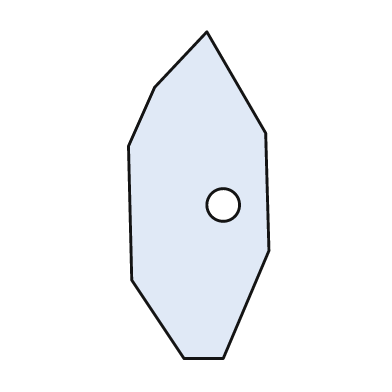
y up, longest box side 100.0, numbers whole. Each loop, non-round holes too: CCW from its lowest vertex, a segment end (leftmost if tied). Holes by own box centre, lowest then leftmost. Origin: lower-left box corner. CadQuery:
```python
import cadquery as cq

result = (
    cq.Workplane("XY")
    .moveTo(17.0, 0.0)
    .lineTo(29.0, 0.0)
    .lineTo(43.0, 33.0)
    .lineTo(42.0, 69.0)
    .lineTo(24.0, 100.0)
    .lineTo(8.0, 83.0)
    .lineTo(0.0, 65.0)
    .lineTo(1.0, 24.0)
    .close()
    .moveTo(29.0, 47.0)
    .circle(5.0)
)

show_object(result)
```